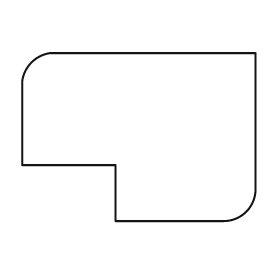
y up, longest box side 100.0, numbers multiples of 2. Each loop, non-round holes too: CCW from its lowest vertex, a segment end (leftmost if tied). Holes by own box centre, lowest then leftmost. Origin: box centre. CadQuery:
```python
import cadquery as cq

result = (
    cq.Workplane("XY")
    .moveTo(-10.0, -36.0)
    .lineTo(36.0, -36.0)
    .threePointArc((46.0, -32.0), (50.0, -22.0))
    .lineTo(50.0, 36.0)
    .lineTo(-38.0, 36.0)
    .threePointArc((-46.0, 32.0), (-50.0, 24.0))
    .lineTo(-50.0, -12.0)
    .lineTo(-10.0, -12.0)
    .close()
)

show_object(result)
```